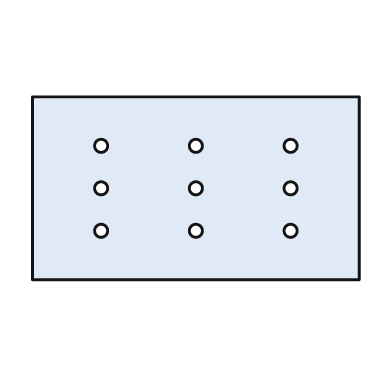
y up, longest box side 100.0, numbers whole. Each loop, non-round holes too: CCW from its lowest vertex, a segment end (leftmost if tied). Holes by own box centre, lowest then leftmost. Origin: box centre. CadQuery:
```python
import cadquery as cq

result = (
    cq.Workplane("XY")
    .moveTo(-50.0, -28.0)
    .lineTo(50.0, -28.0)
    .lineTo(50.0, 28.0)
    .lineTo(-50.0, 28.0)
    .close()
    .moveTo(-29.0, -13.0)
    .circle(2.0)
    .moveTo(0.0, -13.0)
    .circle(2.0)
    .moveTo(29.0, -13.0)
    .circle(2.0)
    .moveTo(-29.0, 0.0)
    .circle(2.0)
    .moveTo(0.0, 0.0)
    .circle(2.0)
    .moveTo(29.0, 0.0)
    .circle(2.0)
    .moveTo(-29.0, 13.0)
    .circle(2.0)
    .moveTo(0.0, 13.0)
    .circle(2.0)
    .moveTo(29.0, 13.0)
    .circle(2.0)
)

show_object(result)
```